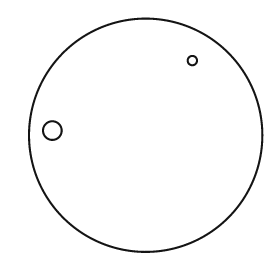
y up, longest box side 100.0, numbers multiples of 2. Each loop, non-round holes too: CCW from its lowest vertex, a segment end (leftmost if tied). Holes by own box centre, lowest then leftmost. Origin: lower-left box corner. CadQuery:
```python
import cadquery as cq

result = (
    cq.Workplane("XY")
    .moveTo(50.0, 50.0)
    .circle(50.0)
    .moveTo(10.0, 52.0)
    .circle(4.0)
    .moveTo(70.0, 82.0)
    .circle(2.0)
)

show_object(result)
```